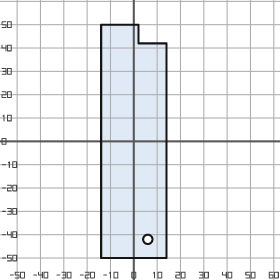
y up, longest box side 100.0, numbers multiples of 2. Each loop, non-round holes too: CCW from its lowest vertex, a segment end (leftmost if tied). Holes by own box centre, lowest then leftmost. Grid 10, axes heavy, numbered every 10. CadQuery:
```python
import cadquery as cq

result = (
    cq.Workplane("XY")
    .moveTo(-14.0, -50.0)
    .lineTo(14.0, -50.0)
    .lineTo(14.0, 42.0)
    .lineTo(2.0, 42.0)
    .lineTo(2.0, 50.0)
    .lineTo(-14.0, 50.0)
    .close()
    .moveTo(6.0, -42.0)
    .circle(2.0)
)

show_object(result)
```